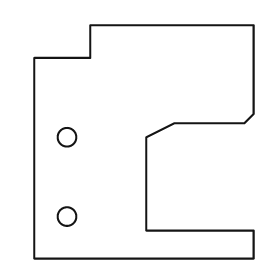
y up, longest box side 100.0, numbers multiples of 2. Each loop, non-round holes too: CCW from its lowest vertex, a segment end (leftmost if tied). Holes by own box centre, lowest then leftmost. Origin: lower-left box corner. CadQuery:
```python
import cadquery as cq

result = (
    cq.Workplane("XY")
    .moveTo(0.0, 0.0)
    .lineTo(94.0, 0.0)
    .lineTo(94.0, 12.0)
    .lineTo(48.0, 12.0)
    .lineTo(48.0, 52.0)
    .lineTo(60.0, 58.0)
    .lineTo(90.0, 58.0)
    .lineTo(94.0, 62.0)
    .lineTo(94.0, 100.0)
    .lineTo(24.0, 100.0)
    .lineTo(24.0, 86.0)
    .lineTo(0.0, 86.0)
    .close()
    .moveTo(14.0, 18.0)
    .circle(4.0)
    .moveTo(14.0, 52.0)
    .circle(4.0)
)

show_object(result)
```